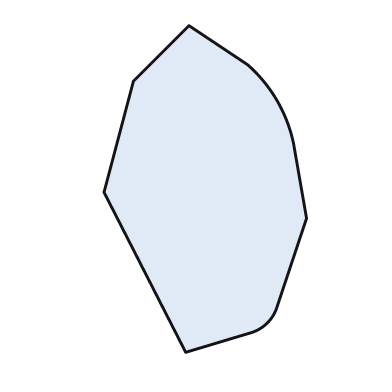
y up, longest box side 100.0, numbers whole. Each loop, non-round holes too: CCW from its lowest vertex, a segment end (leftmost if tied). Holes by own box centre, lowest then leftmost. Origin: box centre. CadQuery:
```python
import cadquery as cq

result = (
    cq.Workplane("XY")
    .moveTo(-6.0, -50.0)
    .lineTo(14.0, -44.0)
    .threePointArc((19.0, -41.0), (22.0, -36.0))
    .lineTo(31.0, -9.0)
    .lineTo(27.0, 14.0)
    .threePointArc((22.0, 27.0), (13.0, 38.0))
    .lineTo(-5.0, 50.0)
    .lineTo(-22.0, 33.0)
    .lineTo(-31.0, -1.0)
    .close()
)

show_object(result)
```